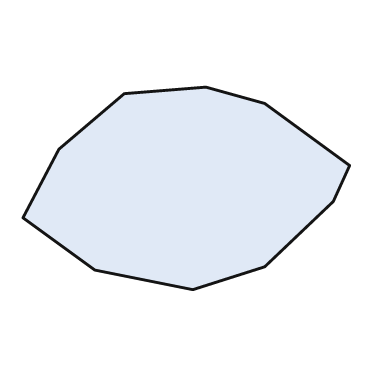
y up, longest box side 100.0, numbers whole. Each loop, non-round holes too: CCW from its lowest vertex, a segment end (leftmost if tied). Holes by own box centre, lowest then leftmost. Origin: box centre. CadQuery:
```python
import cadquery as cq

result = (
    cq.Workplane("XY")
    .moveTo(2.0, -31.0)
    .lineTo(24.0, -24.0)
    .lineTo(45.0, -4.0)
    .lineTo(50.0, 7.0)
    .lineTo(24.0, 26.0)
    .lineTo(6.0, 31.0)
    .lineTo(-19.0, 29.0)
    .lineTo(-39.0, 12.0)
    .lineTo(-50.0, -9.0)
    .lineTo(-28.0, -25.0)
    .close()
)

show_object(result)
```